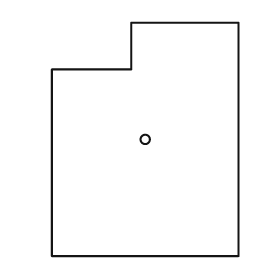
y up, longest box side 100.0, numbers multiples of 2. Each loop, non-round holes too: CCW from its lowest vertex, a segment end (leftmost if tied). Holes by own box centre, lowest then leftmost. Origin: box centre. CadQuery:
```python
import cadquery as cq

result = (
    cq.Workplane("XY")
    .moveTo(-40.0, -50.0)
    .lineTo(40.0, -50.0)
    .lineTo(40.0, 50.0)
    .lineTo(-6.0, 50.0)
    .lineTo(-6.0, 30.0)
    .lineTo(-40.0, 30.0)
    .close()
    .moveTo(0.0, 0.0)
    .circle(2.0)
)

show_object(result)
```